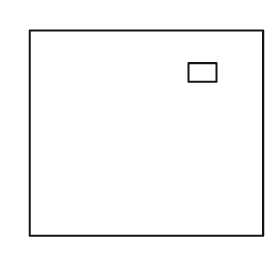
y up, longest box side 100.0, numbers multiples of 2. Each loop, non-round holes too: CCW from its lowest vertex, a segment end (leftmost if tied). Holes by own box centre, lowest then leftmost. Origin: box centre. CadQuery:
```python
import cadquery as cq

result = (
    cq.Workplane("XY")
    .moveTo(-50.0, -44.0)
    .lineTo(50.0, -44.0)
    .lineTo(50.0, 44.0)
    .lineTo(-50.0, 44.0)
    .close()
    .moveTo(18.0, 22.0)
    .lineTo(30.0, 22.0)
    .lineTo(30.0, 30.0)
    .lineTo(18.0, 30.0)
    .close()
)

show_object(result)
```